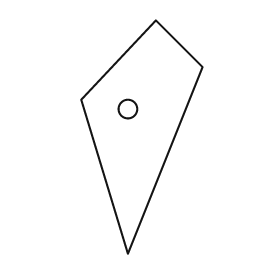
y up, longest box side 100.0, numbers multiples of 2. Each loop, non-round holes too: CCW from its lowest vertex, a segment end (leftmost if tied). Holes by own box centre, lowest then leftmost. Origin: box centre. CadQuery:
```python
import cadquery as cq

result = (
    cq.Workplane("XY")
    .moveTo(-6.0, -50.0)
    .lineTo(26.0, 30.0)
    .lineTo(6.0, 50.0)
    .lineTo(-26.0, 16.0)
    .close()
    .moveTo(-6.0, 12.0)
    .circle(4.0)
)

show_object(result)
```